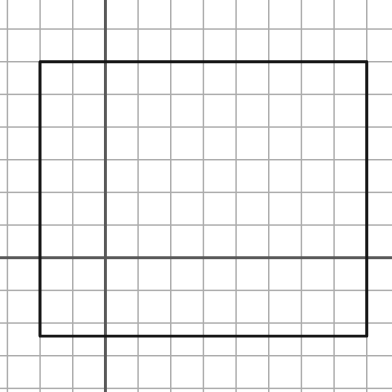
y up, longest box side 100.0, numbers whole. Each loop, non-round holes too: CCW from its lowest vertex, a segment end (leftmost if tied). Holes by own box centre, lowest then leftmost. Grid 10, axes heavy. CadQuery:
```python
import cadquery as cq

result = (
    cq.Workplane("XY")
    .moveTo(-20.0, -24.0)
    .lineTo(80.0, -24.0)
    .lineTo(80.0, 60.0)
    .lineTo(-20.0, 60.0)
    .close()
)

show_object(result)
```